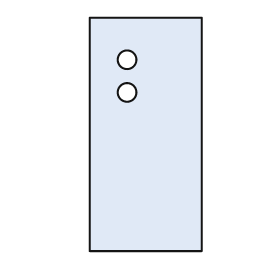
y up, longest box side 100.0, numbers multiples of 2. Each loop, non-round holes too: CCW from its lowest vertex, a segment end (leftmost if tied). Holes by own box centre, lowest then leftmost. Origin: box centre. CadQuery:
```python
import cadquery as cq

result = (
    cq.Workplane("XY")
    .moveTo(-24.0, -50.0)
    .lineTo(24.0, -50.0)
    .lineTo(24.0, 50.0)
    .lineTo(-24.0, 50.0)
    .close()
    .moveTo(-8.0, 18.0)
    .circle(4.0)
    .moveTo(-8.0, 32.0)
    .circle(4.0)
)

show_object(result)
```